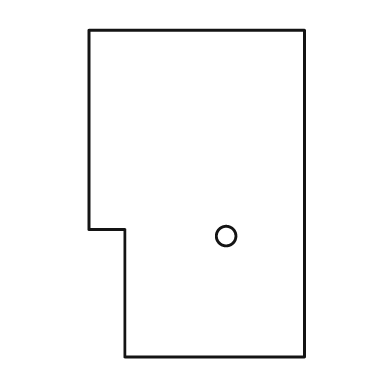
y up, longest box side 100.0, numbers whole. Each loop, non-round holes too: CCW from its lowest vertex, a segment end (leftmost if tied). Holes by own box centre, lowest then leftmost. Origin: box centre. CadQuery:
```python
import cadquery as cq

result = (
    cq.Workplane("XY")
    .moveTo(-22.0, -50.0)
    .lineTo(33.0, -50.0)
    .lineTo(33.0, 50.0)
    .lineTo(-33.0, 50.0)
    .lineTo(-33.0, -11.0)
    .lineTo(-22.0, -11.0)
    .close()
    .moveTo(9.0, -13.0)
    .circle(3.0)
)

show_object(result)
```